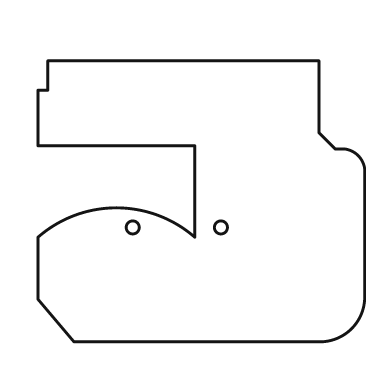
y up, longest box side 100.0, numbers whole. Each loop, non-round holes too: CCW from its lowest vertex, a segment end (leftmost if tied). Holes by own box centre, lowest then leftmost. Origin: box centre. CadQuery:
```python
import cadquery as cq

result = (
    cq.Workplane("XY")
    .moveTo(-39.0, -43.0)
    .lineTo(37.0, -43.0)
    .threePointArc((46.0, -39.0), (50.0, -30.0))
    .lineTo(50.0, 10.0)
    .threePointArc((48.0, 14.0), (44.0, 16.0))
    .lineTo(41.0, 16.0)
    .lineTo(36.0, 21.0)
    .lineTo(36.0, 43.0)
    .lineTo(-47.0, 43.0)
    .lineTo(-47.0, 34.0)
    .lineTo(-50.0, 34.0)
    .lineTo(-50.0, 17.0)
    .lineTo(-2.0, 17.0)
    .lineTo(-2.0, -11.0)
    .threePointArc((-26.0, -2.0), (-50.0, -11.0))
    .lineTo(-50.0, -30.0)
    .close()
    .moveTo(-21.0, -8.0)
    .circle(2.0)
    .moveTo(6.0, -8.0)
    .circle(2.0)
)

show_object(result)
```